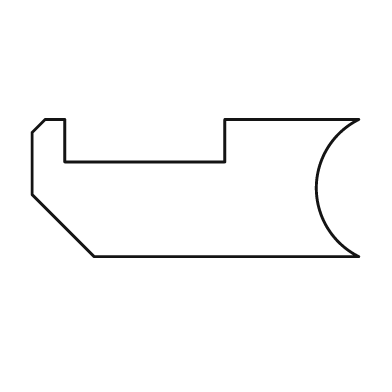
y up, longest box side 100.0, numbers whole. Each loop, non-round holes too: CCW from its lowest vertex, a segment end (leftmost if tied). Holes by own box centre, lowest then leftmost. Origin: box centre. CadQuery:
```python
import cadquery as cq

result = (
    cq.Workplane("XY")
    .moveTo(-31.0, -21.0)
    .lineTo(50.0, -21.0)
    .threePointArc((37.0, 0.0), (50.0, 21.0))
    .lineTo(9.0, 21.0)
    .lineTo(9.0, 8.0)
    .lineTo(-40.0, 8.0)
    .lineTo(-40.0, 21.0)
    .lineTo(-46.0, 21.0)
    .lineTo(-50.0, 17.0)
    .lineTo(-50.0, -2.0)
    .close()
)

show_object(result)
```